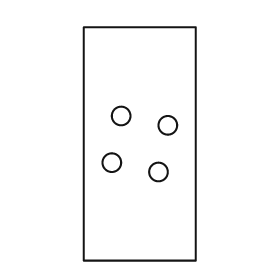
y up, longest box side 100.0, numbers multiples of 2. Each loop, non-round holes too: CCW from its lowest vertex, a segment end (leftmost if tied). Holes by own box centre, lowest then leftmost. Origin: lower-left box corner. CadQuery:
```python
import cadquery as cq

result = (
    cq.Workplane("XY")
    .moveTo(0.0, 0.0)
    .lineTo(48.0, 0.0)
    .lineTo(48.0, 100.0)
    .lineTo(0.0, 100.0)
    .close()
    .moveTo(32.0, 38.0)
    .circle(4.0)
    .moveTo(12.0, 42.0)
    .circle(4.0)
    .moveTo(36.0, 58.0)
    .circle(4.0)
    .moveTo(16.0, 62.0)
    .circle(4.0)
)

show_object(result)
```